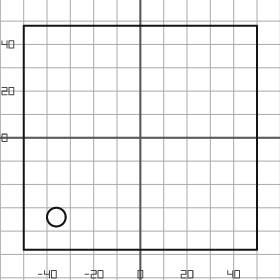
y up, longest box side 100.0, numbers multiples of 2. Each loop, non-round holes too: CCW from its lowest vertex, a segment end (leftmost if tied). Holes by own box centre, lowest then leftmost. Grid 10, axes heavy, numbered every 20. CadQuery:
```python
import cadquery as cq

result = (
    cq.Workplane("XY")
    .moveTo(-50.0, -48.0)
    .lineTo(50.0, -48.0)
    .lineTo(50.0, 48.0)
    .lineTo(-50.0, 48.0)
    .close()
    .moveTo(-36.0, -34.0)
    .circle(4.0)
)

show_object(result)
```